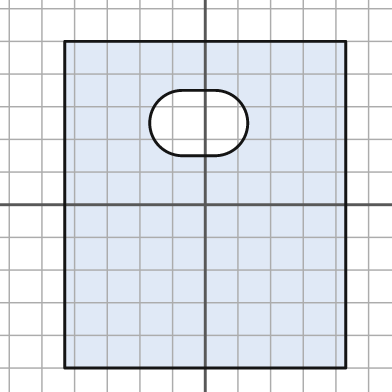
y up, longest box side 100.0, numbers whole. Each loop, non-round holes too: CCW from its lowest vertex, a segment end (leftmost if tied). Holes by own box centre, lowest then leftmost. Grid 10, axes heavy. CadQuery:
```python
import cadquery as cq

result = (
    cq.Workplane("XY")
    .moveTo(-43.0, -50.0)
    .lineTo(43.0, -50.0)
    .lineTo(43.0, 50.0)
    .lineTo(-43.0, 50.0)
    .close()
    .moveTo(-7.0, 15.0)
    .lineTo(3.0, 15.0)
    .threePointArc((13.0, 25.0), (3.0, 35.0))
    .lineTo(-7.0, 35.0)
    .threePointArc((-17.0, 25.0), (-7.0, 15.0))
    .close()
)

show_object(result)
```